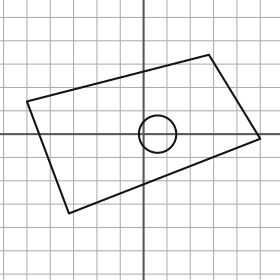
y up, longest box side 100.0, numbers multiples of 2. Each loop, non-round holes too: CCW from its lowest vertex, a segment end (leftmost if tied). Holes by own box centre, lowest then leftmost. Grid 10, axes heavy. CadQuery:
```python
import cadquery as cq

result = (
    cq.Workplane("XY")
    .moveTo(-32.0, -34.0)
    .lineTo(50.0, -2.0)
    .lineTo(28.0, 34.0)
    .lineTo(-50.0, 14.0)
    .close()
    .moveTo(6.0, 0.0)
    .circle(8.0)
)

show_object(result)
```